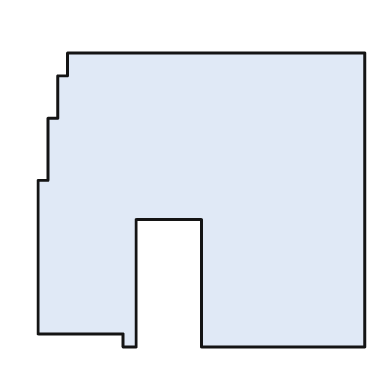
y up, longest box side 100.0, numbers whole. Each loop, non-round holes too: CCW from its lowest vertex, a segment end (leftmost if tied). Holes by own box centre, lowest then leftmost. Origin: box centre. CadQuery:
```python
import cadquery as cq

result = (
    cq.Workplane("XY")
    .moveTo(-24.0, -45.0)
    .lineTo(-20.0, -45.0)
    .lineTo(-20.0, -6.0)
    .lineTo(0.0, -6.0)
    .lineTo(0.0, -45.0)
    .lineTo(50.0, -45.0)
    .lineTo(50.0, 45.0)
    .lineTo(-41.0, 45.0)
    .lineTo(-41.0, 38.0)
    .lineTo(-44.0, 38.0)
    .lineTo(-44.0, 25.0)
    .lineTo(-47.0, 25.0)
    .lineTo(-47.0, 6.0)
    .lineTo(-50.0, 6.0)
    .lineTo(-50.0, -41.0)
    .lineTo(-24.0, -41.0)
    .close()
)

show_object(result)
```